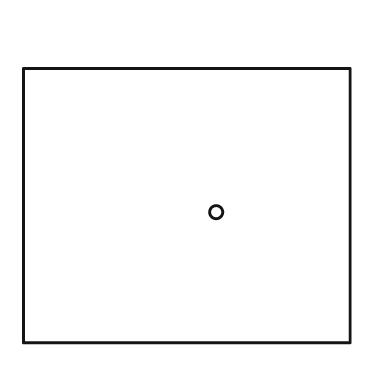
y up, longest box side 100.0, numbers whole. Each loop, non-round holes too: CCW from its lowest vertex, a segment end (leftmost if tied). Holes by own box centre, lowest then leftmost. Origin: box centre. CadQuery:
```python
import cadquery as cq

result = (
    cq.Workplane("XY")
    .moveTo(-50.0, -42.0)
    .lineTo(50.0, -42.0)
    .lineTo(50.0, 42.0)
    .lineTo(-50.0, 42.0)
    .close()
    .moveTo(9.0, -2.0)
    .circle(2.0)
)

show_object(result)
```